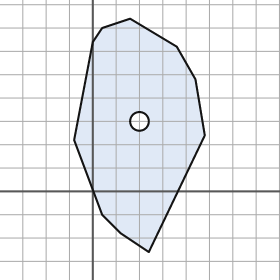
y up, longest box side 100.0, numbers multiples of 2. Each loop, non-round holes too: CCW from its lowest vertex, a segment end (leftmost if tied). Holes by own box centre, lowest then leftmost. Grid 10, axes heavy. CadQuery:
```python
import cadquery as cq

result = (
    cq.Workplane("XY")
    .moveTo(24.0, -26.0)
    .lineTo(48.0, 24.0)
    .lineTo(44.0, 48.0)
    .lineTo(36.0, 62.0)
    .lineTo(16.0, 74.0)
    .lineTo(4.0, 70.0)
    .lineTo(0.0, 64.0)
    .lineTo(-8.0, 22.0)
    .lineTo(4.0, -10.0)
    .lineTo(12.0, -18.0)
    .close()
    .moveTo(20.0, 30.0)
    .circle(4.0)
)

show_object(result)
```